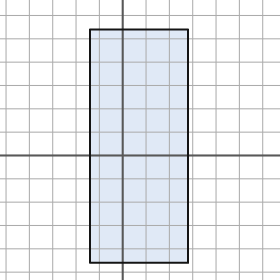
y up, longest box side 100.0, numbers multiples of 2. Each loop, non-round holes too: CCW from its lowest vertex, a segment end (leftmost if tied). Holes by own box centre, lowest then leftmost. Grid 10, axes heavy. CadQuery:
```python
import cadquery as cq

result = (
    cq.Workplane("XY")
    .moveTo(-14.0, -46.0)
    .lineTo(28.0, -46.0)
    .lineTo(28.0, 54.0)
    .lineTo(-14.0, 54.0)
    .close()
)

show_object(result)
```